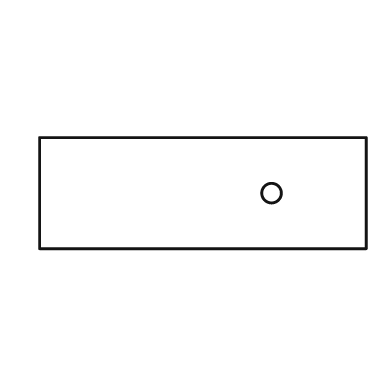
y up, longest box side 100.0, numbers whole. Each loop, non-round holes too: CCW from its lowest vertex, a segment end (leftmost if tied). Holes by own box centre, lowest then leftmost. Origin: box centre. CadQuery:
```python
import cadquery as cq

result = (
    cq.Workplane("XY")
    .moveTo(-50.0, -17.0)
    .lineTo(50.0, -17.0)
    .lineTo(50.0, 17.0)
    .lineTo(-50.0, 17.0)
    .close()
    .moveTo(21.0, 0.0)
    .circle(3.0)
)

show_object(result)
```